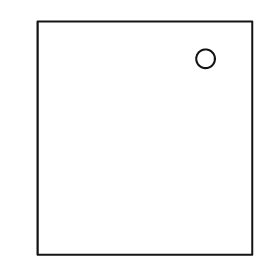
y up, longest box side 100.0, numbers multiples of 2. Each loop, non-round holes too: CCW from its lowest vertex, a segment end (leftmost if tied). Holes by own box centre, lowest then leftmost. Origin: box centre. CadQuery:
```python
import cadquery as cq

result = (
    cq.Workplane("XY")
    .moveTo(-46.0, -50.0)
    .lineTo(46.0, -50.0)
    .lineTo(46.0, 50.0)
    .lineTo(-46.0, 50.0)
    .close()
    .moveTo(26.0, 34.0)
    .circle(4.0)
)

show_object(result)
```